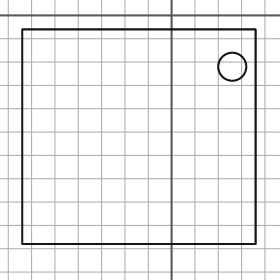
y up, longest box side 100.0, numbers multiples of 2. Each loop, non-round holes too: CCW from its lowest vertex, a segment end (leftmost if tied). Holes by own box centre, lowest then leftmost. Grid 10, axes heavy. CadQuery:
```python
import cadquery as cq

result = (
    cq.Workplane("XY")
    .moveTo(-64.0, -98.0)
    .lineTo(36.0, -98.0)
    .lineTo(36.0, -6.0)
    .lineTo(-64.0, -6.0)
    .close()
    .moveTo(26.0, -22.0)
    .circle(6.0)
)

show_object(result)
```